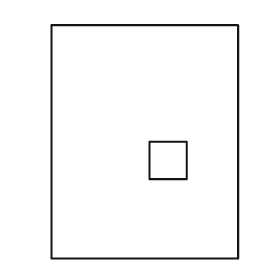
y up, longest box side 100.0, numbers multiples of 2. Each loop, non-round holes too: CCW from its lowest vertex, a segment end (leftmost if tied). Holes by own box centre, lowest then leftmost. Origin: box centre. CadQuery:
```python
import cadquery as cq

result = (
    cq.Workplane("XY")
    .moveTo(-40.0, -50.0)
    .lineTo(40.0, -50.0)
    .lineTo(40.0, 50.0)
    .lineTo(-40.0, 50.0)
    .close()
    .moveTo(2.0, -16.0)
    .lineTo(18.0, -16.0)
    .lineTo(18.0, 0.0)
    .lineTo(2.0, 0.0)
    .close()
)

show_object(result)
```